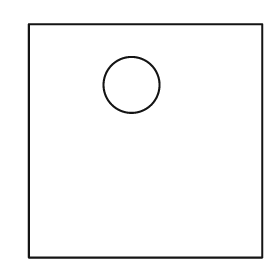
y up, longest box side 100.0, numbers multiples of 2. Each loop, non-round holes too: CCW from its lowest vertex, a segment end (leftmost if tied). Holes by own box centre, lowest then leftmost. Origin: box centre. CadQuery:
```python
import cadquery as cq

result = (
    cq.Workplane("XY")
    .moveTo(-50.0, -50.0)
    .lineTo(50.0, -50.0)
    .lineTo(50.0, 50.0)
    .lineTo(-50.0, 50.0)
    .close()
    .moveTo(-6.0, 24.0)
    .circle(12.0)
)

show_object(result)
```